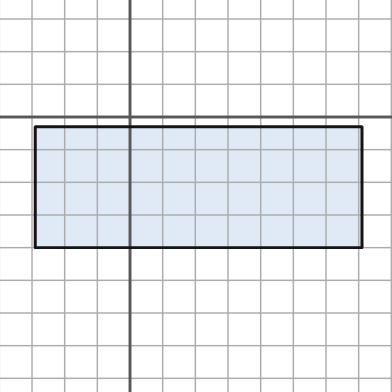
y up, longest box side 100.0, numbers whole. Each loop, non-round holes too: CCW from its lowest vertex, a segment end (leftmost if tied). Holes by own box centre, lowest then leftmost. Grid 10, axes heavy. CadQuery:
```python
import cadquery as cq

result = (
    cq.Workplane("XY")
    .moveTo(-29.0, -40.0)
    .lineTo(71.0, -40.0)
    .lineTo(71.0, -3.0)
    .lineTo(-29.0, -3.0)
    .close()
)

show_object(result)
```